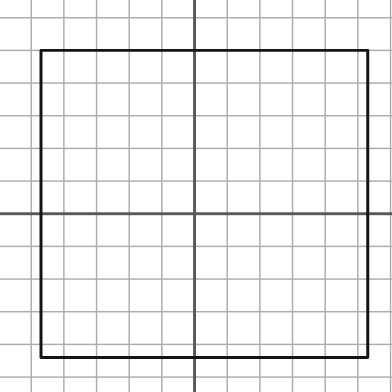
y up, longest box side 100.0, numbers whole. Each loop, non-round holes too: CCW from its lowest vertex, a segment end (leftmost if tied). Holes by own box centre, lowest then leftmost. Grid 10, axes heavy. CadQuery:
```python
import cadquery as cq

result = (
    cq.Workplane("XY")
    .moveTo(-47.0, -44.0)
    .lineTo(53.0, -44.0)
    .lineTo(53.0, 50.0)
    .lineTo(-47.0, 50.0)
    .close()
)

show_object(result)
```